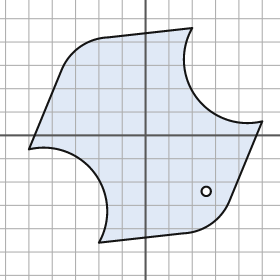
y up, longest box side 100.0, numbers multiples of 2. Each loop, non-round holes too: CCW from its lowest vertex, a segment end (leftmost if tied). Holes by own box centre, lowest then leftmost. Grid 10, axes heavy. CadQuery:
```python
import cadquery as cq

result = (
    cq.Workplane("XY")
    .moveTo(-20.0, -46.0)
    .lineTo(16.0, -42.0)
    .threePointArc((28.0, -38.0), (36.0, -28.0))
    .lineTo(50.0, 6.0)
    .threePointArc((22.0, 16.0), (20.0, 46.0))
    .lineTo(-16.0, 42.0)
    .threePointArc((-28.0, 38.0), (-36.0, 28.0))
    .lineTo(-50.0, -6.0)
    .threePointArc((-22.0, -16.0), (-20.0, -46.0))
    .close()
    .moveTo(26.0, -24.0)
    .circle(2.0)
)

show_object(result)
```